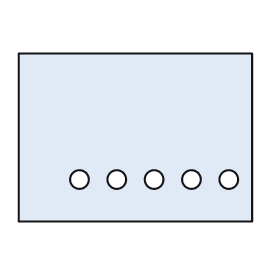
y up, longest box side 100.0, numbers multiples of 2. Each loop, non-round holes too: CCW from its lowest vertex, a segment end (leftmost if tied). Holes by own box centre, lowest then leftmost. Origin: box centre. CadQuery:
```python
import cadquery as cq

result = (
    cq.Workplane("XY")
    .moveTo(-50.0, -36.0)
    .lineTo(50.0, -36.0)
    .lineTo(50.0, 36.0)
    .lineTo(-50.0, 36.0)
    .close()
    .moveTo(-24.0, -18.0)
    .circle(4.0)
    .moveTo(-8.0, -18.0)
    .circle(4.0)
    .moveTo(8.0, -18.0)
    .circle(4.0)
    .moveTo(24.0, -18.0)
    .circle(4.0)
    .moveTo(40.0, -18.0)
    .circle(4.0)
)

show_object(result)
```